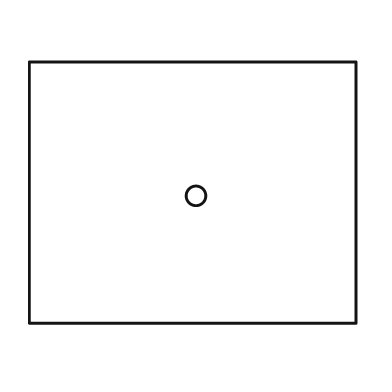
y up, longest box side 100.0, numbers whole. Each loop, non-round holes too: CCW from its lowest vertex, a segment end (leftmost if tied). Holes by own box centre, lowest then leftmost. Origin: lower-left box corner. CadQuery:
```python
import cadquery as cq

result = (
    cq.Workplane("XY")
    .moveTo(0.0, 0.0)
    .lineTo(100.0, 0.0)
    .lineTo(100.0, 80.0)
    .lineTo(0.0, 80.0)
    .close()
    .moveTo(51.0, 39.0)
    .circle(3.0)
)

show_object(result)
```